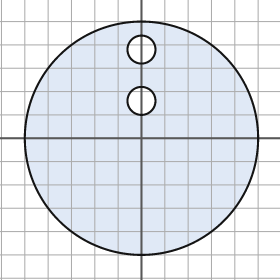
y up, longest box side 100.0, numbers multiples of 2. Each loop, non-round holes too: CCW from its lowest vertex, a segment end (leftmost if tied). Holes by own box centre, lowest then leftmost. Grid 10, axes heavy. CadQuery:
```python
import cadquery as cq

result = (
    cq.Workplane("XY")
    .moveTo(0.0, 0.0)
    .circle(50.0)
    .moveTo(0.0, 16.0)
    .circle(6.0)
    .moveTo(0.0, 38.0)
    .circle(6.0)
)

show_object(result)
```